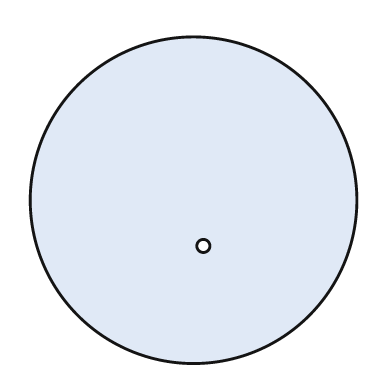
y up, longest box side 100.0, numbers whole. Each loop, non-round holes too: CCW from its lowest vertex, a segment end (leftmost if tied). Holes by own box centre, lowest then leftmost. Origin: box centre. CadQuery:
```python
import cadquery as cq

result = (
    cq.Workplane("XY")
    .moveTo(0.0, 0.0)
    .circle(50.0)
    .moveTo(3.0, -14.0)
    .circle(2.0)
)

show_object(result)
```